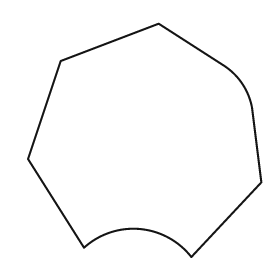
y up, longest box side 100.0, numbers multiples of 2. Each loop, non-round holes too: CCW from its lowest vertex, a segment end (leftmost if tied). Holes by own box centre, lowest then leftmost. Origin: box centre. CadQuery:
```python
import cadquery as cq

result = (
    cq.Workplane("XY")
    .moveTo(20.0, -50.0)
    .lineTo(50.0, -18.0)
    .lineTo(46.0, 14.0)
    .threePointArc((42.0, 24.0), (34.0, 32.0))
    .lineTo(6.0, 50.0)
    .lineTo(-36.0, 34.0)
    .lineTo(-50.0, -8.0)
    .lineTo(-26.0, -46.0)
    .threePointArc((-2.0, -38.0), (20.0, -50.0))
    .close()
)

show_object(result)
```